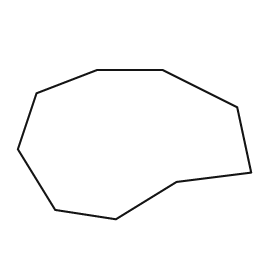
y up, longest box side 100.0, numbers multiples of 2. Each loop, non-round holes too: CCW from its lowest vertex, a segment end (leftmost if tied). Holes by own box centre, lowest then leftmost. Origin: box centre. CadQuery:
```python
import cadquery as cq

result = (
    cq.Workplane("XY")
    .moveTo(-8.0, -32.0)
    .lineTo(18.0, -16.0)
    .lineTo(50.0, -12.0)
    .lineTo(44.0, 16.0)
    .lineTo(12.0, 32.0)
    .lineTo(-16.0, 32.0)
    .lineTo(-42.0, 22.0)
    .lineTo(-50.0, -2.0)
    .lineTo(-34.0, -28.0)
    .close()
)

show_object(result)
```